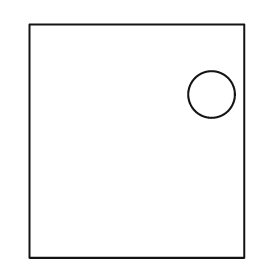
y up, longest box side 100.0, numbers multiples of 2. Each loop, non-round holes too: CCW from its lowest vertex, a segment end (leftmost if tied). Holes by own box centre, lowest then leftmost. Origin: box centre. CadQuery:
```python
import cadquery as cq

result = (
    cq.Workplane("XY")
    .moveTo(-46.0, -50.0)
    .lineTo(46.0, -50.0)
    .lineTo(46.0, 50.0)
    .lineTo(-46.0, 50.0)
    .close()
    .moveTo(32.0, 20.0)
    .circle(10.0)
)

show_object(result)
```